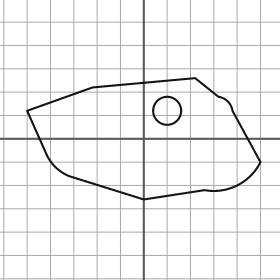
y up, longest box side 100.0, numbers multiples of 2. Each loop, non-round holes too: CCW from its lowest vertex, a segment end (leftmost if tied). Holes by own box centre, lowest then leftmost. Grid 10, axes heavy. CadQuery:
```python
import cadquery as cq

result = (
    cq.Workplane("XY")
    .moveTo(0.0, -26.0)
    .lineTo(26.0, -22.0)
    .threePointArc((40.0, -20.0), (50.0, -10.0))
    .lineTo(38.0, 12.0)
    .threePointArc((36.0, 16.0), (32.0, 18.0))
    .lineTo(22.0, 26.0)
    .lineTo(-22.0, 22.0)
    .lineTo(-50.0, 12.0)
    .lineTo(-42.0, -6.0)
    .threePointArc((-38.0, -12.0), (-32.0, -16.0))
    .close()
    .moveTo(10.0, 12.0)
    .circle(6.0)
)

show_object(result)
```